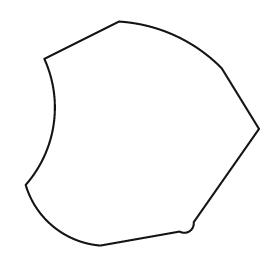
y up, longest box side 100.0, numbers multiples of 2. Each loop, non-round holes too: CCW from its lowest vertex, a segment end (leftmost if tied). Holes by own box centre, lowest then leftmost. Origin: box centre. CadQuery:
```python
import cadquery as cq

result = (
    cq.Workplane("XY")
    .moveTo(-18.0, -48.0)
    .lineTo(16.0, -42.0)
    .threePointArc((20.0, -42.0), (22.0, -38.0))
    .lineTo(50.0, 2.0)
    .lineTo(34.0, 28.0)
    .threePointArc((14.0, 42.0), (-10.0, 48.0))
    .lineTo(-42.0, 32.0)
    .threePointArc((-38.0, 4.0), (-50.0, -22.0))
    .threePointArc((-38.0, -40.0), (-18.0, -48.0))
    .close()
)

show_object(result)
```